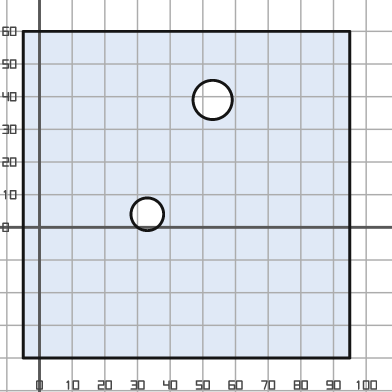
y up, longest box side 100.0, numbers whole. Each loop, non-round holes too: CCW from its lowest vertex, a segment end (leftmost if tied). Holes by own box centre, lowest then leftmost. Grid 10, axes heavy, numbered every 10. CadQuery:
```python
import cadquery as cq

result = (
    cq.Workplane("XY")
    .moveTo(-5.0, -40.0)
    .lineTo(95.0, -40.0)
    .lineTo(95.0, 60.0)
    .lineTo(-5.0, 60.0)
    .close()
    .moveTo(33.0, 4.0)
    .circle(5.0)
    .moveTo(53.0, 39.0)
    .circle(6.0)
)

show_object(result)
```